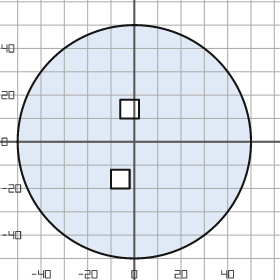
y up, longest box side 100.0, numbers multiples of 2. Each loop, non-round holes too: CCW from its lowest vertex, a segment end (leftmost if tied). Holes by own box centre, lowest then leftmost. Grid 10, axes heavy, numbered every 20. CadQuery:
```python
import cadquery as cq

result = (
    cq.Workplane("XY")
    .moveTo(0.0, 0.0)
    .circle(50.0)
    .moveTo(-10.0, -20.0)
    .lineTo(-2.0, -20.0)
    .lineTo(-2.0, -12.0)
    .lineTo(-10.0, -12.0)
    .close()
    .moveTo(-6.0, 10.0)
    .lineTo(2.0, 10.0)
    .lineTo(2.0, 18.0)
    .lineTo(-6.0, 18.0)
    .close()
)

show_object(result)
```